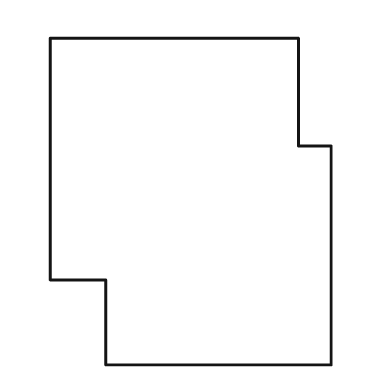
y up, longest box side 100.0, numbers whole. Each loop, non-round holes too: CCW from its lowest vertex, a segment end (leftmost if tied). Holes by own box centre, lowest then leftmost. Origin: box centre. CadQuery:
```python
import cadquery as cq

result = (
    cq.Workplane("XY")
    .moveTo(-26.0, -50.0)
    .lineTo(43.0, -50.0)
    .lineTo(43.0, 17.0)
    .lineTo(33.0, 17.0)
    .lineTo(33.0, 50.0)
    .lineTo(-43.0, 50.0)
    .lineTo(-43.0, -24.0)
    .lineTo(-26.0, -24.0)
    .close()
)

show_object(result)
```